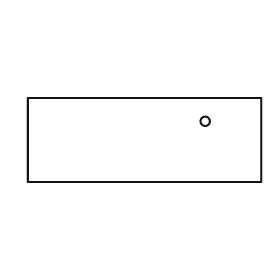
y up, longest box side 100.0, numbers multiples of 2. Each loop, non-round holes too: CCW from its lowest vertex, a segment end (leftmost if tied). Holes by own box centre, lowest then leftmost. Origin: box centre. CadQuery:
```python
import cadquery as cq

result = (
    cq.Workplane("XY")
    .moveTo(-50.0, -18.0)
    .lineTo(50.0, -18.0)
    .lineTo(50.0, 18.0)
    .lineTo(-50.0, 18.0)
    .close()
    .moveTo(26.0, 8.0)
    .circle(2.0)
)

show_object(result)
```